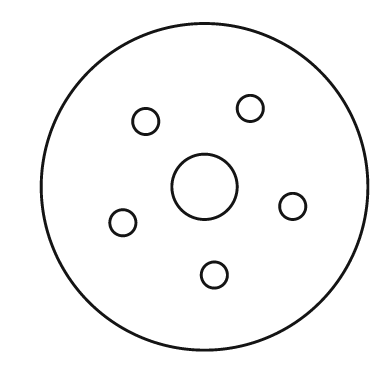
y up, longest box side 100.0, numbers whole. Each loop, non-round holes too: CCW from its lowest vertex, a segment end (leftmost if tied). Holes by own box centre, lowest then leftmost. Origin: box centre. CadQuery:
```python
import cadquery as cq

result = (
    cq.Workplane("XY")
    .moveTo(0.0, 0.0)
    .circle(50.0)
    .moveTo(3.0, -27.0)
    .circle(4.0)
    .moveTo(-25.0, -11.0)
    .circle(4.0)
    .moveTo(27.0, -6.0)
    .circle(4.0)
    .moveTo(0.0, 0.0)
    .circle(10.0)
    .moveTo(-18.0, 20.0)
    .circle(4.0)
    .moveTo(14.0, 24.0)
    .circle(4.0)
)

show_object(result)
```